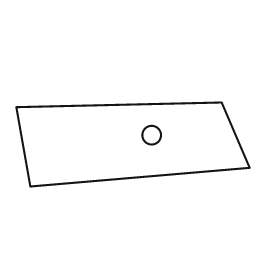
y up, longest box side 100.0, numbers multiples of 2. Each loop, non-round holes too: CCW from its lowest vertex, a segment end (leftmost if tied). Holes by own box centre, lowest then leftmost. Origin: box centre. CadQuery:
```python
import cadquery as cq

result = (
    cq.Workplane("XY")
    .moveTo(-44.0, -18.0)
    .lineTo(50.0, -10.0)
    .lineTo(38.0, 18.0)
    .lineTo(-50.0, 16.0)
    .close()
    .moveTo(8.0, 4.0)
    .circle(4.0)
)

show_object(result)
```